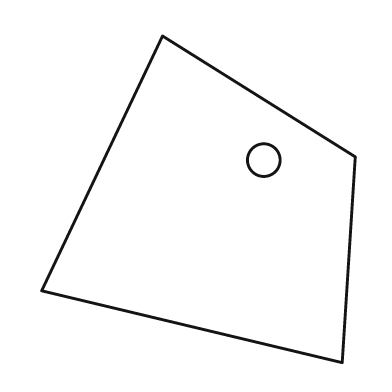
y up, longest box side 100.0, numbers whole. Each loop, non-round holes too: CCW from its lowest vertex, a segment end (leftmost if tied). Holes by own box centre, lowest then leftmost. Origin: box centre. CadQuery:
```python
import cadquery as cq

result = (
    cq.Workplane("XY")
    .moveTo(44.0, -50.0)
    .lineTo(48.0, 13.0)
    .lineTo(-11.0, 50.0)
    .lineTo(-48.0, -28.0)
    .close()
    .moveTo(20.0, 12.0)
    .circle(5.0)
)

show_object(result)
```